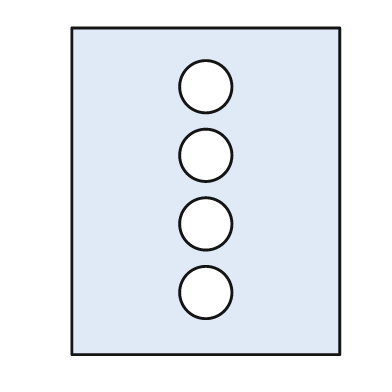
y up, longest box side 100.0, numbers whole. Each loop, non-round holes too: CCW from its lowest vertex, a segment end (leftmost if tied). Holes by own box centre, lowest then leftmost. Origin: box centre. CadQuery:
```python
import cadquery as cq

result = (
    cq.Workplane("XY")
    .moveTo(-41.0, -50.0)
    .lineTo(41.0, -50.0)
    .lineTo(41.0, 50.0)
    .lineTo(-41.0, 50.0)
    .close()
    .moveTo(0.0, -31.0)
    .circle(8.0)
    .moveTo(0.0, -10.0)
    .circle(8.0)
    .moveTo(0.0, 11.0)
    .circle(8.0)
    .moveTo(0.0, 32.0)
    .circle(8.0)
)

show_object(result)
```